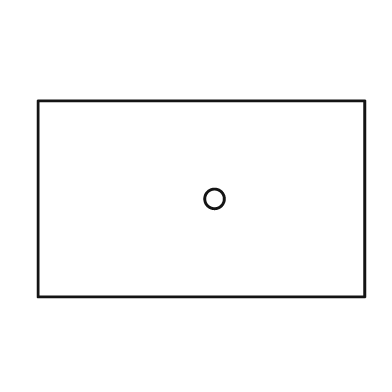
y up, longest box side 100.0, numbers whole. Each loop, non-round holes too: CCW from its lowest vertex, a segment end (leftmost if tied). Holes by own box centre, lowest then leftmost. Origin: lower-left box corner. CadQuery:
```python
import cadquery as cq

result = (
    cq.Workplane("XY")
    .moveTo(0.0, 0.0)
    .lineTo(100.0, 0.0)
    .lineTo(100.0, 60.0)
    .lineTo(0.0, 60.0)
    .close()
    .moveTo(54.0, 30.0)
    .circle(3.0)
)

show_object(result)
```